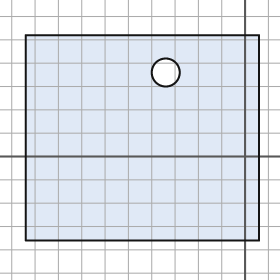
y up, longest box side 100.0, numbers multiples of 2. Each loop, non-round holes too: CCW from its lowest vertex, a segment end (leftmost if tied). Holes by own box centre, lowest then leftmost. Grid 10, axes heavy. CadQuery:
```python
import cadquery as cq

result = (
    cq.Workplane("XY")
    .moveTo(-94.0, -36.0)
    .lineTo(6.0, -36.0)
    .lineTo(6.0, 52.0)
    .lineTo(-94.0, 52.0)
    .close()
    .moveTo(-34.0, 36.0)
    .circle(6.0)
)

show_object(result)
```